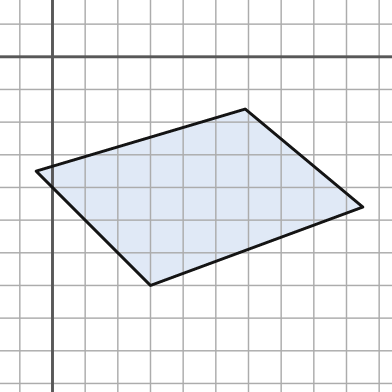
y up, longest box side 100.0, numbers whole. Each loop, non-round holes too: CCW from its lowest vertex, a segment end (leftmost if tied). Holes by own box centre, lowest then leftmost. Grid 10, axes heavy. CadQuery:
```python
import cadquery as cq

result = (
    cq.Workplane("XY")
    .moveTo(30.0, -70.0)
    .lineTo(95.0, -46.0)
    .lineTo(59.0, -16.0)
    .lineTo(-5.0, -35.0)
    .close()
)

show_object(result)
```